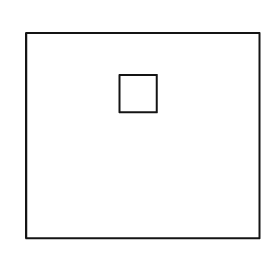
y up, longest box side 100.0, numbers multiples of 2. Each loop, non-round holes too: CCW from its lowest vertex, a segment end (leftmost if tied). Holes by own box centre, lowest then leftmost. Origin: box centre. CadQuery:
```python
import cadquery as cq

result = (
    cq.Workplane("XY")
    .moveTo(-50.0, -44.0)
    .lineTo(50.0, -44.0)
    .lineTo(50.0, 44.0)
    .lineTo(-50.0, 44.0)
    .close()
    .moveTo(-10.0, 10.0)
    .lineTo(6.0, 10.0)
    .lineTo(6.0, 26.0)
    .lineTo(-10.0, 26.0)
    .close()
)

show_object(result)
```